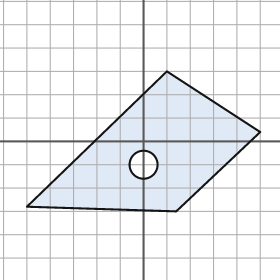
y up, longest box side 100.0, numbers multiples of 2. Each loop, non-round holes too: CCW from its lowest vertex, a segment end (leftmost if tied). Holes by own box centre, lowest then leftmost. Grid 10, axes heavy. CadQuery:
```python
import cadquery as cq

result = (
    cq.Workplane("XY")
    .moveTo(14.0, -30.0)
    .lineTo(50.0, 4.0)
    .lineTo(10.0, 30.0)
    .lineTo(-50.0, -28.0)
    .close()
    .moveTo(0.0, -10.0)
    .circle(6.0)
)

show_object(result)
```